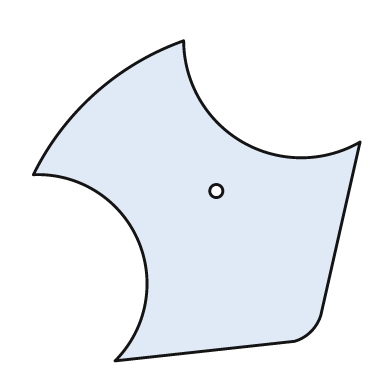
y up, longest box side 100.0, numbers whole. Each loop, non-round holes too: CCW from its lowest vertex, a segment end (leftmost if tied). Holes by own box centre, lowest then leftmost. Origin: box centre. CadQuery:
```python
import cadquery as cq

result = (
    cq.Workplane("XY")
    .moveTo(-25.0, -49.0)
    .lineTo(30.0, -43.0)
    .threePointArc((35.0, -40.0), (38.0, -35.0))
    .lineTo(50.0, 18.0)
    .threePointArc((14.0, 18.0), (-4.0, 49.0))
    .threePointArc((-31.0, 33.0), (-50.0, 8.0))
    .threePointArc((-18.0, -12.0), (-25.0, -49.0))
    .close()
    .moveTo(6.0, 3.0)
    .circle(2.0)
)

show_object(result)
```